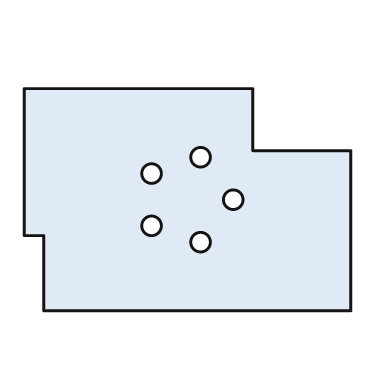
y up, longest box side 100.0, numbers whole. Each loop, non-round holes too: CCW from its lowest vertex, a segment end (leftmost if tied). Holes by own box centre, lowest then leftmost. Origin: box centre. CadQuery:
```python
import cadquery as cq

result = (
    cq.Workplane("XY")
    .moveTo(-44.0, -34.0)
    .lineTo(50.0, -34.0)
    .lineTo(50.0, 15.0)
    .lineTo(20.0, 15.0)
    .lineTo(20.0, 34.0)
    .lineTo(-50.0, 34.0)
    .lineTo(-50.0, -11.0)
    .lineTo(-44.0, -11.0)
    .close()
    .moveTo(4.0, -13.0)
    .circle(3.0)
    .moveTo(-11.0, -8.0)
    .circle(3.0)
    .moveTo(14.0, 0.0)
    .circle(3.0)
    .moveTo(-11.0, 8.0)
    .circle(3.0)
    .moveTo(4.0, 13.0)
    .circle(3.0)
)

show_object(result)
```